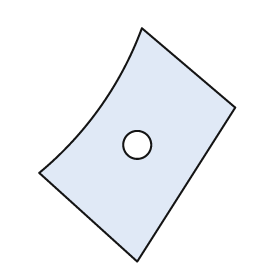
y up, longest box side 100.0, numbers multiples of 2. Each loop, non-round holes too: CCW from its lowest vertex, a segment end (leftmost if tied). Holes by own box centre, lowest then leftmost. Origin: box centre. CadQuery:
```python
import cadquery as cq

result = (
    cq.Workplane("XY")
    .moveTo(0.0, -50.0)
    .lineTo(42.0, 16.0)
    .lineTo(2.0, 50.0)
    .threePointArc((-16.0, 16.0), (-42.0, -12.0))
    .close()
    .moveTo(0.0, 0.0)
    .circle(6.0)
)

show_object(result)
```